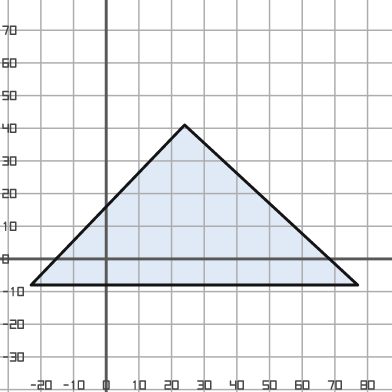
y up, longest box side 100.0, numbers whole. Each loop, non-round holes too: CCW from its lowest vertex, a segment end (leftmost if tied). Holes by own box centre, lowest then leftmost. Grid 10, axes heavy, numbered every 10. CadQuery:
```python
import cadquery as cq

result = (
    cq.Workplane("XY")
    .moveTo(-23.0, -8.0)
    .lineTo(77.0, -8.0)
    .lineTo(24.0, 41.0)
    .close()
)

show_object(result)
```